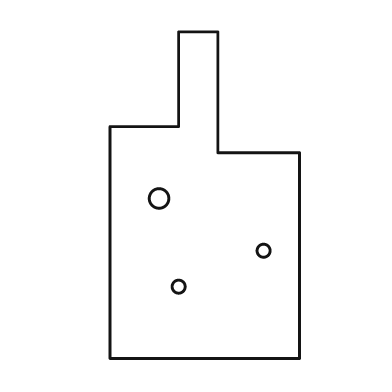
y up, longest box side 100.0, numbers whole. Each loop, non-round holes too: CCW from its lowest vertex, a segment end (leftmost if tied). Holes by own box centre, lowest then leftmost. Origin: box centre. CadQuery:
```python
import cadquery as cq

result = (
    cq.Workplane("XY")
    .moveTo(-29.0, -50.0)
    .lineTo(29.0, -50.0)
    .lineTo(29.0, 13.0)
    .lineTo(4.0, 13.0)
    .lineTo(4.0, 50.0)
    .lineTo(-8.0, 50.0)
    .lineTo(-8.0, 21.0)
    .lineTo(-29.0, 21.0)
    .close()
    .moveTo(-8.0, -28.0)
    .circle(2.0)
    .moveTo(18.0, -17.0)
    .circle(2.0)
    .moveTo(-14.0, -1.0)
    .circle(3.0)
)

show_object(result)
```